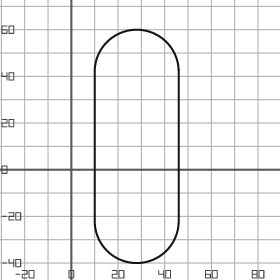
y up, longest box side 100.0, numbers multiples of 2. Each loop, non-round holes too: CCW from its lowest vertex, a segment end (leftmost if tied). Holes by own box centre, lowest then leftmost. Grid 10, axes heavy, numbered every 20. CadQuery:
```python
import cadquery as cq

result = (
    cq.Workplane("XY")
    .moveTo(10.0, -22.0)
    .threePointArc((28.0, -40.0), (46.0, -22.0))
    .lineTo(46.0, 42.0)
    .threePointArc((28.0, 60.0), (10.0, 42.0))
    .close()
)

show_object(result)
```